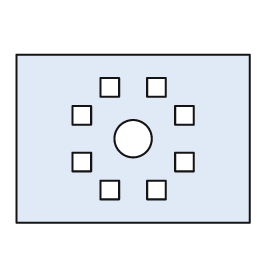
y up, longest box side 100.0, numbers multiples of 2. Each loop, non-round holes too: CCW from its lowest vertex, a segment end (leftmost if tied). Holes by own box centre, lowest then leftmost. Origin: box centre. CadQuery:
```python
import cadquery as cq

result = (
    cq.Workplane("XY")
    .moveTo(-50.0, -36.0)
    .lineTo(50.0, -36.0)
    .lineTo(50.0, 36.0)
    .lineTo(-50.0, 36.0)
    .close()
    .moveTo(-14.0, -26.0)
    .lineTo(-6.0, -26.0)
    .lineTo(-6.0, -18.0)
    .lineTo(-14.0, -18.0)
    .close()
    .moveTo(6.0, -26.0)
    .lineTo(14.0, -26.0)
    .lineTo(14.0, -18.0)
    .lineTo(6.0, -18.0)
    .close()
    .moveTo(-26.0, -14.0)
    .lineTo(-18.0, -14.0)
    .lineTo(-18.0, -6.0)
    .lineTo(-26.0, -6.0)
    .close()
    .moveTo(18.0, -14.0)
    .lineTo(26.0, -14.0)
    .lineTo(26.0, -6.0)
    .lineTo(18.0, -6.0)
    .close()
    .moveTo(0.0, 0.0)
    .circle(8.0)
    .moveTo(-26.0, 6.0)
    .lineTo(-18.0, 6.0)
    .lineTo(-18.0, 14.0)
    .lineTo(-26.0, 14.0)
    .close()
    .moveTo(18.0, 6.0)
    .lineTo(26.0, 6.0)
    .lineTo(26.0, 14.0)
    .lineTo(18.0, 14.0)
    .close()
    .moveTo(-14.0, 18.0)
    .lineTo(-6.0, 18.0)
    .lineTo(-6.0, 26.0)
    .lineTo(-14.0, 26.0)
    .close()
    .moveTo(6.0, 18.0)
    .lineTo(14.0, 18.0)
    .lineTo(14.0, 26.0)
    .lineTo(6.0, 26.0)
    .close()
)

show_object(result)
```